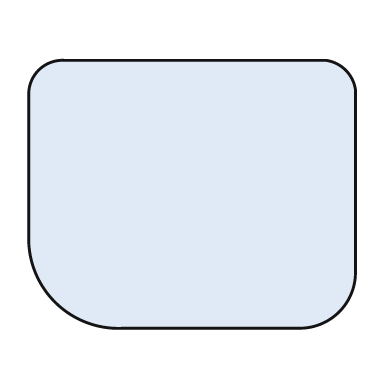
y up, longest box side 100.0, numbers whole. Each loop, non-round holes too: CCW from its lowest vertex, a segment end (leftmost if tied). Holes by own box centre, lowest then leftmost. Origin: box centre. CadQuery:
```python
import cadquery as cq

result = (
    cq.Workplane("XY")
    .moveTo(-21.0, -41.0)
    .lineTo(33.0, -41.0)
    .threePointArc((45.0, -36.0), (50.0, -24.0))
    .lineTo(50.0, 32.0)
    .threePointArc((47.0, 38.0), (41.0, 41.0))
    .lineTo(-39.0, 41.0)
    .threePointArc((-47.0, 38.0), (-50.0, 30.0))
    .lineTo(-50.0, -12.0)
    .threePointArc((-42.0, -33.0), (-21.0, -41.0))
    .close()
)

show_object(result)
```